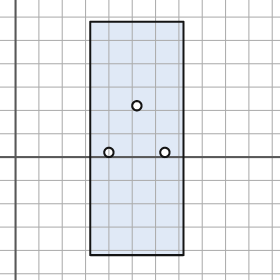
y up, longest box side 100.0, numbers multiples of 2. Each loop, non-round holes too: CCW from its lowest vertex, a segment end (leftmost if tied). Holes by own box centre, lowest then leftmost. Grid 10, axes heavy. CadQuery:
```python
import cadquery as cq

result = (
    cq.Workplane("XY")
    .moveTo(32.0, -42.0)
    .lineTo(72.0, -42.0)
    .lineTo(72.0, 58.0)
    .lineTo(32.0, 58.0)
    .close()
    .moveTo(40.0, 2.0)
    .circle(2.0)
    .moveTo(64.0, 2.0)
    .circle(2.0)
    .moveTo(52.0, 22.0)
    .circle(2.0)
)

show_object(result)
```